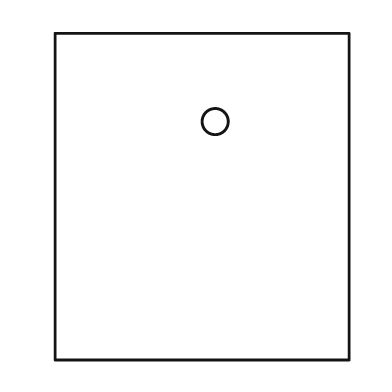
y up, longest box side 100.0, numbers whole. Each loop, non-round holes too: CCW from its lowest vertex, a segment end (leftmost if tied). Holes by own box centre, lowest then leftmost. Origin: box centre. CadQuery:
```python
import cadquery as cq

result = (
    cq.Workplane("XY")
    .moveTo(-45.0, -50.0)
    .lineTo(45.0, -50.0)
    .lineTo(45.0, 50.0)
    .lineTo(-45.0, 50.0)
    .close()
    .moveTo(4.0, 23.0)
    .circle(4.0)
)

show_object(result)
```